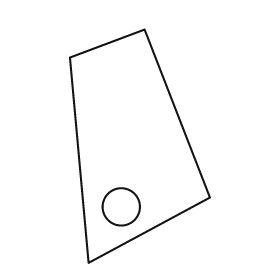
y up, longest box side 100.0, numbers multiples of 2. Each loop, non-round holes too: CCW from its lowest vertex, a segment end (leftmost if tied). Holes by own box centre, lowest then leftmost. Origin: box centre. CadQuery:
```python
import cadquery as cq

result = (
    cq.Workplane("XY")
    .moveTo(-22.0, -50.0)
    .lineTo(30.0, -22.0)
    .lineTo(2.0, 50.0)
    .lineTo(-30.0, 38.0)
    .close()
    .moveTo(-8.0, -26.0)
    .circle(8.0)
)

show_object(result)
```